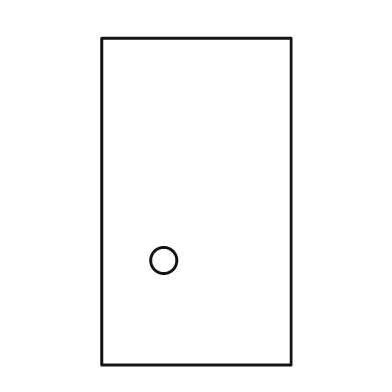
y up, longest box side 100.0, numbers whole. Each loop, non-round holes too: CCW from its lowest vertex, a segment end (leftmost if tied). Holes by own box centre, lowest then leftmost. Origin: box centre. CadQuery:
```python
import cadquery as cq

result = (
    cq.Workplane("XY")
    .moveTo(-29.0, -50.0)
    .lineTo(29.0, -50.0)
    .lineTo(29.0, 50.0)
    .lineTo(-29.0, 50.0)
    .close()
    .moveTo(-10.0, -18.0)
    .circle(4.0)
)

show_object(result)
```